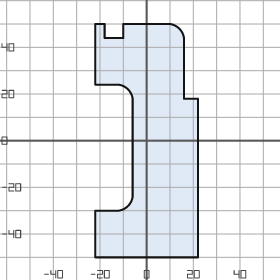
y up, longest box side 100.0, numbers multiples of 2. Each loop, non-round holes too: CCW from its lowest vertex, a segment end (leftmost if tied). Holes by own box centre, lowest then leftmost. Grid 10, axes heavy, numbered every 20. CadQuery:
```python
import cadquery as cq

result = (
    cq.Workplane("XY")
    .moveTo(-22.0, -50.0)
    .lineTo(22.0, -50.0)
    .lineTo(22.0, 18.0)
    .lineTo(16.0, 18.0)
    .lineTo(16.0, 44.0)
    .threePointArc((14.0, 48.0), (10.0, 50.0))
    .lineTo(-10.0, 50.0)
    .lineTo(-10.0, 44.0)
    .lineTo(-18.0, 44.0)
    .lineTo(-18.0, 50.0)
    .lineTo(-22.0, 50.0)
    .lineTo(-22.0, 24.0)
    .lineTo(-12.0, 24.0)
    .threePointArc((-8.0, 22.0), (-6.0, 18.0))
    .lineTo(-6.0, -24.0)
    .threePointArc((-8.0, -28.0), (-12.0, -30.0))
    .lineTo(-22.0, -30.0)
    .close()
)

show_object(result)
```